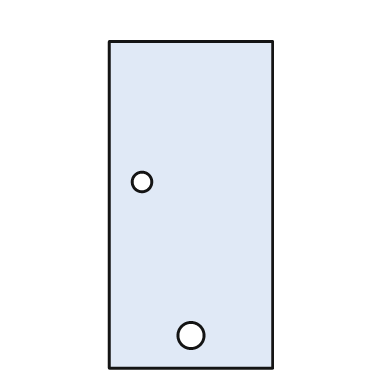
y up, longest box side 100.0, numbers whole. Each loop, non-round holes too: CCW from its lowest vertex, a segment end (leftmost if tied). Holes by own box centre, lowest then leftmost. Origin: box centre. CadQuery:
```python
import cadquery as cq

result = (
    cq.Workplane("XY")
    .moveTo(-25.0, -50.0)
    .lineTo(25.0, -50.0)
    .lineTo(25.0, 50.0)
    .lineTo(-25.0, 50.0)
    .close()
    .moveTo(0.0, -40.0)
    .circle(4.0)
    .moveTo(-15.0, 7.0)
    .circle(3.0)
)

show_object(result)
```